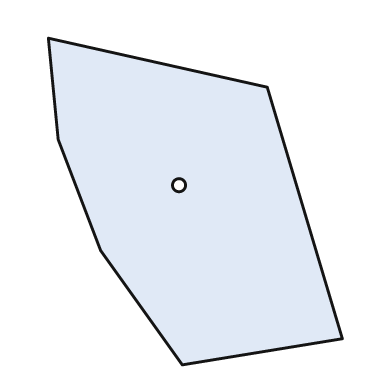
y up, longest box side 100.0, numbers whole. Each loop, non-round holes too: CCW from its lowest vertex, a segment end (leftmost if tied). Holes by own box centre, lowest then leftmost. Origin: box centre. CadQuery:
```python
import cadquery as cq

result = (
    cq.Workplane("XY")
    .moveTo(-4.0, -50.0)
    .lineTo(45.0, -42.0)
    .lineTo(22.0, 35.0)
    .lineTo(-45.0, 50.0)
    .lineTo(-42.0, 19.0)
    .lineTo(-29.0, -15.0)
    .close()
    .moveTo(-5.0, 5.0)
    .circle(2.0)
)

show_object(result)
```